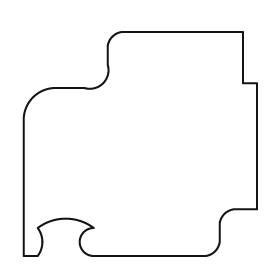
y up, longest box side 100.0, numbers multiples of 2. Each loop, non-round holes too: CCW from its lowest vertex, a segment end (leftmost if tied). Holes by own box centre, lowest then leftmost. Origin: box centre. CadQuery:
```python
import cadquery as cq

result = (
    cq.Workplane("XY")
    .moveTo(-50.0, -48.0)
    .lineTo(-44.0, -48.0)
    .threePointArc((-42.0, -42.0), (-44.0, -36.0))
    .threePointArc((-32.0, -32.0), (-20.0, -36.0))
    .threePointArc((-26.0, -42.0), (-20.0, -48.0))
    .lineTo(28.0, -48.0)
    .threePointArc((32.0, -46.0), (34.0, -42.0))
    .lineTo(34.0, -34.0)
    .threePointArc((36.0, -30.0), (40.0, -28.0))
    .lineTo(50.0, -28.0)
    .lineTo(50.0, 26.0)
    .lineTo(44.0, 26.0)
    .lineTo(44.0, 48.0)
    .lineTo(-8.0, 48.0)
    .threePointArc((-12.0, 46.0), (-14.0, 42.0))
    .lineTo(-14.0, 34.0)
    .threePointArc((-16.0, 26.0), (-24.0, 24.0))
    .lineTo(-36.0, 24.0)
    .threePointArc((-46.0, 20.0), (-50.0, 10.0))
    .close()
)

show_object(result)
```